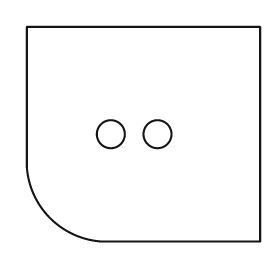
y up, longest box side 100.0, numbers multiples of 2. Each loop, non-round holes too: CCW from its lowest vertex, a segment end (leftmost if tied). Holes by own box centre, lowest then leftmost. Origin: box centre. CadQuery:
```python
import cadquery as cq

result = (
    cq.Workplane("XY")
    .moveTo(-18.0, -46.0)
    .lineTo(50.0, -46.0)
    .lineTo(50.0, 46.0)
    .lineTo(-50.0, 46.0)
    .lineTo(-50.0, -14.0)
    .threePointArc((-40.0, -36.0), (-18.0, -46.0))
    .close()
    .moveTo(-14.0, 0.0)
    .circle(6.0)
    .moveTo(6.0, 0.0)
    .circle(6.0)
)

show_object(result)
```